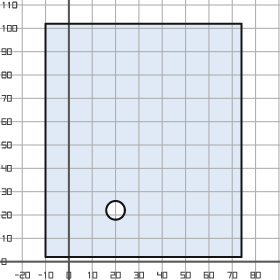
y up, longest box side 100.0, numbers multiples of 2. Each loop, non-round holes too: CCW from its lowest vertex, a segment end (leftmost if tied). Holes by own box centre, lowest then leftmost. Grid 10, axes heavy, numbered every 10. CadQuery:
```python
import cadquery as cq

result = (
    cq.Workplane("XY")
    .moveTo(-10.0, 2.0)
    .lineTo(74.0, 2.0)
    .lineTo(74.0, 102.0)
    .lineTo(-10.0, 102.0)
    .close()
    .moveTo(20.0, 22.0)
    .circle(4.0)
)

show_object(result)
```